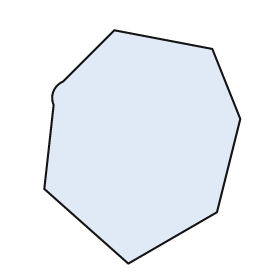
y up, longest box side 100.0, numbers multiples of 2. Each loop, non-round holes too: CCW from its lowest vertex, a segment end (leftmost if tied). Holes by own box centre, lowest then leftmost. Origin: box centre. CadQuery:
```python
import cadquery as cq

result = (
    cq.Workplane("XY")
    .moveTo(-6.0, -50.0)
    .lineTo(32.0, -28.0)
    .lineTo(42.0, 12.0)
    .lineTo(30.0, 42.0)
    .lineTo(-12.0, 50.0)
    .lineTo(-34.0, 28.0)
    .threePointArc((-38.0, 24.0), (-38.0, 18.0))
    .lineTo(-42.0, -18.0)
    .close()
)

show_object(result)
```